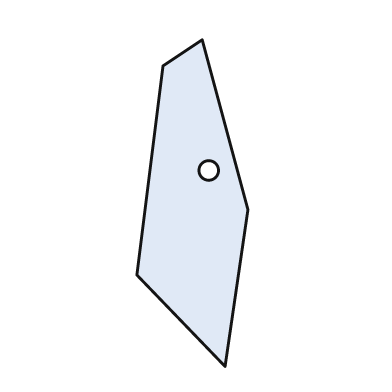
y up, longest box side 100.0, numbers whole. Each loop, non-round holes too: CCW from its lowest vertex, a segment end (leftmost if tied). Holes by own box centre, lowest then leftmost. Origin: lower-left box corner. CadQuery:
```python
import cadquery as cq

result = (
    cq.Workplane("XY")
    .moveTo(27.0, 0.0)
    .lineTo(34.0, 48.0)
    .lineTo(20.0, 100.0)
    .lineTo(8.0, 92.0)
    .lineTo(0.0, 28.0)
    .close()
    .moveTo(22.0, 60.0)
    .circle(3.0)
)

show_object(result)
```